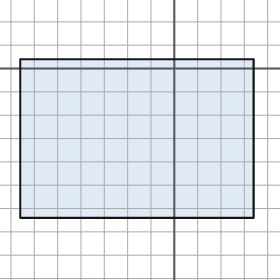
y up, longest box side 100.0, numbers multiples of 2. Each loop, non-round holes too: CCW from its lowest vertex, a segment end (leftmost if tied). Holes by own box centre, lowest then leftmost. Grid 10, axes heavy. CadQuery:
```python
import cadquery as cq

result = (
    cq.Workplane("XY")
    .moveTo(-66.0, -64.0)
    .lineTo(34.0, -64.0)
    .lineTo(34.0, 4.0)
    .lineTo(-66.0, 4.0)
    .close()
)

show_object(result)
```